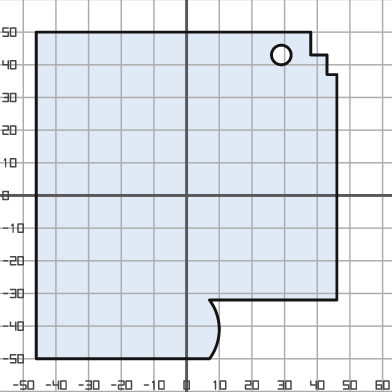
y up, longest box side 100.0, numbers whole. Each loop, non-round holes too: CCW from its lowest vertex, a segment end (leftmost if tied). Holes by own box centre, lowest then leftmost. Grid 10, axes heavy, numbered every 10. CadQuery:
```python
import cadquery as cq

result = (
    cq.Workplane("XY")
    .moveTo(-46.0, -50.0)
    .lineTo(7.0, -50.0)
    .threePointArc((10.0, -41.0), (7.0, -32.0))
    .lineTo(46.0, -32.0)
    .lineTo(46.0, 37.0)
    .lineTo(43.0, 37.0)
    .lineTo(43.0, 43.0)
    .lineTo(38.0, 43.0)
    .lineTo(38.0, 50.0)
    .lineTo(-46.0, 50.0)
    .close()
    .moveTo(29.0, 43.0)
    .circle(3.0)
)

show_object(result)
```